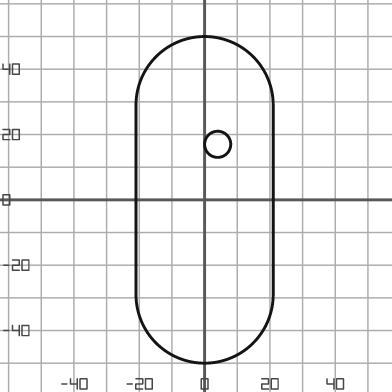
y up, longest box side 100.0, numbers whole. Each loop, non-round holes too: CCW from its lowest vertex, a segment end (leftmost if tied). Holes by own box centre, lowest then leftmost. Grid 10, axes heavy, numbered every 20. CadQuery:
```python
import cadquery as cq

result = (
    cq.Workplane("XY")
    .moveTo(-21.0, -29.0)
    .threePointArc((0.0, -50.0), (21.0, -29.0))
    .lineTo(21.0, 29.0)
    .threePointArc((0.0, 50.0), (-21.0, 29.0))
    .close()
    .moveTo(4.0, 17.0)
    .circle(4.0)
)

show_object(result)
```